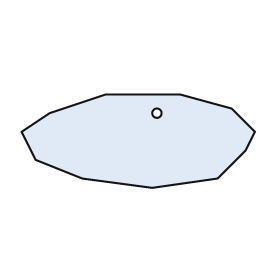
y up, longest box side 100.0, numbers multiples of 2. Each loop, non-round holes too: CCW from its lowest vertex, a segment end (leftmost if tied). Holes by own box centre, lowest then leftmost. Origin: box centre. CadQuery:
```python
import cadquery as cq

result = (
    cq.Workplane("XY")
    .moveTo(6.0, -20.0)
    .lineTo(34.0, -16.0)
    .lineTo(46.0, -4.0)
    .lineTo(50.0, 4.0)
    .lineTo(40.0, 14.0)
    .lineTo(18.0, 20.0)
    .lineTo(-14.0, 20.0)
    .lineTo(-38.0, 12.0)
    .lineTo(-50.0, 4.0)
    .lineTo(-44.0, -8.0)
    .lineTo(-24.0, -16.0)
    .close()
    .moveTo(8.0, 12.0)
    .circle(2.0)
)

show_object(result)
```